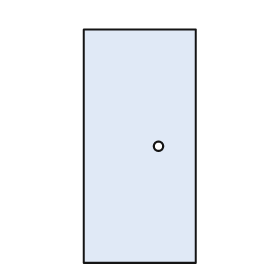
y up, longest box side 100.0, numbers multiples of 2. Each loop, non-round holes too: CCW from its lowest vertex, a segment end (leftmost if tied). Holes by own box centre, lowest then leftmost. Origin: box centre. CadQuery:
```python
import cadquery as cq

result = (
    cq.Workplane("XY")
    .moveTo(-24.0, -50.0)
    .lineTo(24.0, -50.0)
    .lineTo(24.0, 50.0)
    .lineTo(-24.0, 50.0)
    .close()
    .moveTo(8.0, 0.0)
    .circle(2.0)
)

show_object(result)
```